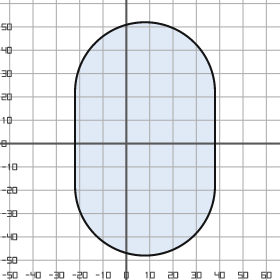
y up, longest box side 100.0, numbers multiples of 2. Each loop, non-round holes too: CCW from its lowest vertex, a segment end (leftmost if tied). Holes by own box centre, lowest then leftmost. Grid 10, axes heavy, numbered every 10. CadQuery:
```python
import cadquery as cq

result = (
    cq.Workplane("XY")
    .moveTo(-22.0, -18.0)
    .threePointArc((8.0, -48.0), (38.0, -18.0))
    .lineTo(38.0, 22.0)
    .threePointArc((8.0, 52.0), (-22.0, 22.0))
    .close()
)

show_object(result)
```